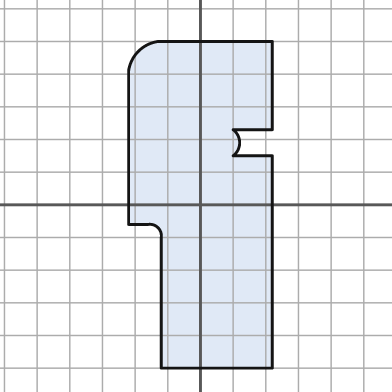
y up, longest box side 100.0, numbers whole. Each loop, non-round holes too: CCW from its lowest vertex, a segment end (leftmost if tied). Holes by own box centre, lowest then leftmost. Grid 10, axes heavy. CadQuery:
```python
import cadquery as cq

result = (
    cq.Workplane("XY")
    .moveTo(-12.0, -50.0)
    .lineTo(22.0, -50.0)
    .lineTo(22.0, 15.0)
    .lineTo(10.0, 15.0)
    .threePointArc((12.0, 19.0), (10.0, 23.0))
    .lineTo(22.0, 23.0)
    .lineTo(22.0, 50.0)
    .lineTo(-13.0, 50.0)
    .threePointArc((-19.0, 47.0), (-22.0, 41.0))
    .lineTo(-22.0, -6.0)
    .lineTo(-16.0, -6.0)
    .threePointArc((-13.0, -7.0), (-12.0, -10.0))
    .close()
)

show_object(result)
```